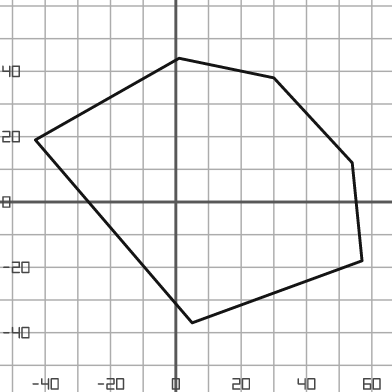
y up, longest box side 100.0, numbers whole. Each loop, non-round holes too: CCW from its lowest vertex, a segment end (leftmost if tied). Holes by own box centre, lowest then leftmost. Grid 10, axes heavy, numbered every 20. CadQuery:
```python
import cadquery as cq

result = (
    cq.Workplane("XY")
    .moveTo(5.0, -37.0)
    .lineTo(57.0, -18.0)
    .lineTo(54.0, 12.0)
    .lineTo(30.0, 38.0)
    .lineTo(1.0, 44.0)
    .lineTo(-43.0, 19.0)
    .close()
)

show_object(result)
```